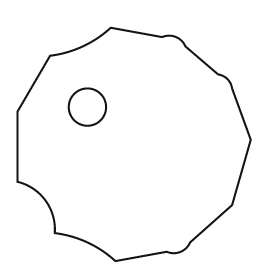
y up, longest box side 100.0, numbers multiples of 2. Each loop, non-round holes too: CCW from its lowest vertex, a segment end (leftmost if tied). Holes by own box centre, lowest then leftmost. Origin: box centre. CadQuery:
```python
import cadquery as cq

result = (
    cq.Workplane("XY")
    .moveTo(-8.0, -50.0)
    .lineTo(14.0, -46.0)
    .threePointArc((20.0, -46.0), (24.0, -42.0))
    .lineTo(42.0, -26.0)
    .lineTo(50.0, 2.0)
    .lineTo(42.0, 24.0)
    .threePointArc((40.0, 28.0), (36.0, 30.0))
    .lineTo(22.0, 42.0)
    .threePointArc((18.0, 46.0), (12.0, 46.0))
    .lineTo(-10.0, 50.0)
    .threePointArc((-22.0, 42.0), (-36.0, 38.0))
    .lineTo(-50.0, 14.0)
    .lineTo(-50.0, -16.0)
    .threePointArc((-38.0, -24.0), (-34.0, -38.0))
    .threePointArc((-20.0, -42.0), (-8.0, -50.0))
    .close()
    .moveTo(-20.0, 16.0)
    .circle(8.0)
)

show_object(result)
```